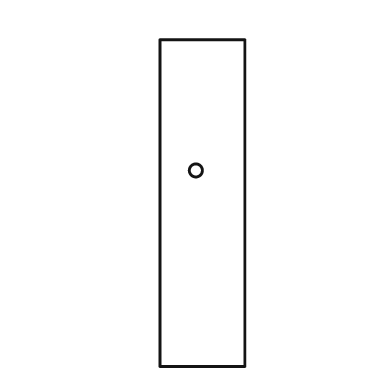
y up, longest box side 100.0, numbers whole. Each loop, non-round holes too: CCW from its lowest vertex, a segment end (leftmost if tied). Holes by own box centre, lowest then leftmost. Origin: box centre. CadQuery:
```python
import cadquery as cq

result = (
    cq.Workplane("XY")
    .moveTo(-13.0, -50.0)
    .lineTo(13.0, -50.0)
    .lineTo(13.0, 50.0)
    .lineTo(-13.0, 50.0)
    .close()
    .moveTo(-2.0, 10.0)
    .circle(2.0)
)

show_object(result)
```